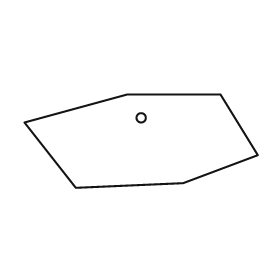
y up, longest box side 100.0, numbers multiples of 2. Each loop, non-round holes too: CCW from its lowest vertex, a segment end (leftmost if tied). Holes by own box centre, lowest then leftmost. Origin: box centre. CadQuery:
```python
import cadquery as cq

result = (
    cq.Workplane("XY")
    .moveTo(-28.0, -20.0)
    .lineTo(18.0, -18.0)
    .lineTo(50.0, -6.0)
    .lineTo(34.0, 20.0)
    .lineTo(-6.0, 20.0)
    .lineTo(-50.0, 8.0)
    .close()
    .moveTo(0.0, 10.0)
    .circle(2.0)
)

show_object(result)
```